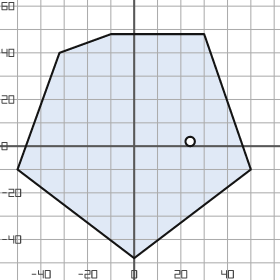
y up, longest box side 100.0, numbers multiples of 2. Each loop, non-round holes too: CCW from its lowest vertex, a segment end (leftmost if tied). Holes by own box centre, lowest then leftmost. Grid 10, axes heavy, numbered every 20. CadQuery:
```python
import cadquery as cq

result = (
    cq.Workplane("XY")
    .moveTo(0.0, -48.0)
    .lineTo(50.0, -10.0)
    .lineTo(30.0, 48.0)
    .lineTo(-10.0, 48.0)
    .lineTo(-32.0, 40.0)
    .lineTo(-50.0, -10.0)
    .close()
    .moveTo(24.0, 2.0)
    .circle(2.0)
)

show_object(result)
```